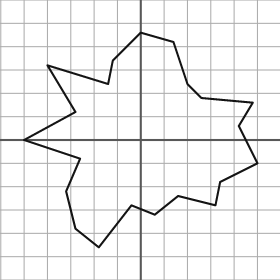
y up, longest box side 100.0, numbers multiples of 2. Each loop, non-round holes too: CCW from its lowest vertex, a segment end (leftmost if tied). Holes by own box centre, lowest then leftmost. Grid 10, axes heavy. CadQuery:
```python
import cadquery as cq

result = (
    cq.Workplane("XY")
    .moveTo(-18.0, -46.0)
    .lineTo(-4.0, -28.0)
    .lineTo(6.0, -32.0)
    .lineTo(16.0, -24.0)
    .lineTo(32.0, -28.0)
    .lineTo(34.0, -18.0)
    .lineTo(50.0, -10.0)
    .lineTo(42.0, 6.0)
    .lineTo(48.0, 16.0)
    .lineTo(26.0, 18.0)
    .lineTo(20.0, 24.0)
    .lineTo(14.0, 42.0)
    .lineTo(0.0, 46.0)
    .lineTo(-12.0, 34.0)
    .lineTo(-14.0, 24.0)
    .lineTo(-40.0, 32.0)
    .lineTo(-28.0, 12.0)
    .lineTo(-50.0, 0.0)
    .lineTo(-26.0, -8.0)
    .lineTo(-32.0, -22.0)
    .lineTo(-28.0, -38.0)
    .close()
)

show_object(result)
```